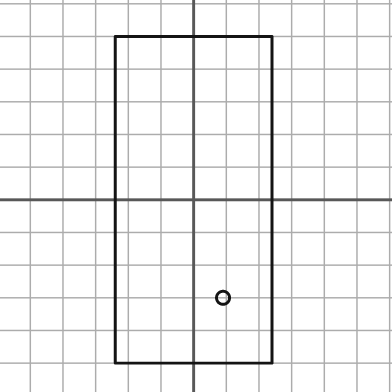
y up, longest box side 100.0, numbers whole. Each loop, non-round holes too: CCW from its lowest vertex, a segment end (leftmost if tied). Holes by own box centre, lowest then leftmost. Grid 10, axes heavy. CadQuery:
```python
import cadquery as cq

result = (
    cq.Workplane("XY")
    .moveTo(-24.0, -50.0)
    .lineTo(24.0, -50.0)
    .lineTo(24.0, 50.0)
    .lineTo(-24.0, 50.0)
    .close()
    .moveTo(9.0, -30.0)
    .circle(2.0)
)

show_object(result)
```